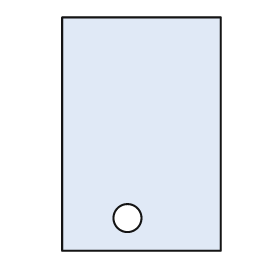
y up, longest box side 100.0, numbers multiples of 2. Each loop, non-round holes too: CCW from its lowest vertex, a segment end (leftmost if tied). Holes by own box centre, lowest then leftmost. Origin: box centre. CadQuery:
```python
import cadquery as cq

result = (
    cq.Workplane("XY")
    .moveTo(-34.0, -50.0)
    .lineTo(34.0, -50.0)
    .lineTo(34.0, 50.0)
    .lineTo(-34.0, 50.0)
    .close()
    .moveTo(-6.0, -36.0)
    .circle(6.0)
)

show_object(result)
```